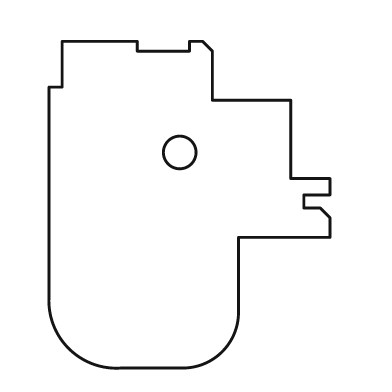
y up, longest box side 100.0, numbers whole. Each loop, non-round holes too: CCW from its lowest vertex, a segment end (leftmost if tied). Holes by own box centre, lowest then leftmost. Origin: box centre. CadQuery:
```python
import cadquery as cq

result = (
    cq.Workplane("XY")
    .moveTo(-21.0, -50.0)
    .lineTo(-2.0, -50.0)
    .threePointArc((10.0, -45.0), (15.0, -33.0))
    .lineTo(15.0, -10.0)
    .lineTo(43.0, -10.0)
    .lineTo(43.0, -4.0)
    .lineTo(40.0, -1.0)
    .lineTo(35.0, -1.0)
    .lineTo(35.0, 3.0)
    .lineTo(43.0, 3.0)
    .lineTo(43.0, 8.0)
    .lineTo(31.0, 8.0)
    .lineTo(31.0, 32.0)
    .lineTo(7.0, 32.0)
    .lineTo(7.0, 47.0)
    .lineTo(4.0, 50.0)
    .lineTo(0.0, 50.0)
    .lineTo(0.0, 47.0)
    .lineTo(-16.0, 47.0)
    .lineTo(-16.0, 50.0)
    .lineTo(-39.0, 50.0)
    .lineTo(-39.0, 36.0)
    .lineTo(-43.0, 36.0)
    .lineTo(-43.0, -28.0)
    .threePointArc((-37.0, -44.0), (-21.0, -50.0))
    .close()
    .moveTo(-3.0, 16.0)
    .circle(5.0)
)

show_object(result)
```